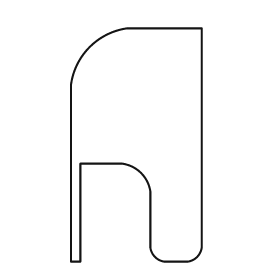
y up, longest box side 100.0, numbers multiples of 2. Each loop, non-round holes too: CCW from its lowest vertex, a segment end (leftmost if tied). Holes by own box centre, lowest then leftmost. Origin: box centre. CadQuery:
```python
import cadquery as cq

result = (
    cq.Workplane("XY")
    .moveTo(-28.0, -50.0)
    .lineTo(-24.0, -50.0)
    .lineTo(-24.0, -8.0)
    .lineTo(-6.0, -8.0)
    .threePointArc((2.0, -12.0), (6.0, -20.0))
    .lineTo(6.0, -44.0)
    .threePointArc((8.0, -48.0), (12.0, -50.0))
    .lineTo(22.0, -50.0)
    .threePointArc((26.0, -48.0), (28.0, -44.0))
    .lineTo(28.0, 50.0)
    .lineTo(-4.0, 50.0)
    .threePointArc((-20.0, 42.0), (-28.0, 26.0))
    .close()
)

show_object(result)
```